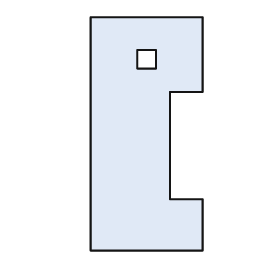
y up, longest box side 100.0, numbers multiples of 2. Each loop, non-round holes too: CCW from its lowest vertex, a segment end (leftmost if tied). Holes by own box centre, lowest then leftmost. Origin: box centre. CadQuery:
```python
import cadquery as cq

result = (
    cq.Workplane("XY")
    .moveTo(-24.0, -50.0)
    .lineTo(24.0, -50.0)
    .lineTo(24.0, -28.0)
    .lineTo(10.0, -28.0)
    .lineTo(10.0, 18.0)
    .lineTo(24.0, 18.0)
    .lineTo(24.0, 50.0)
    .lineTo(-24.0, 50.0)
    .close()
    .moveTo(-4.0, 28.0)
    .lineTo(4.0, 28.0)
    .lineTo(4.0, 36.0)
    .lineTo(-4.0, 36.0)
    .close()
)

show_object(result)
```